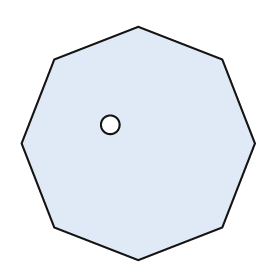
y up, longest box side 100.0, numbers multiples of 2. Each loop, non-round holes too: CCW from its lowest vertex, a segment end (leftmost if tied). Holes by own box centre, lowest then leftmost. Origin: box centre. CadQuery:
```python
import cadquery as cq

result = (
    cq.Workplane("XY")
    .moveTo(0.0, -50.0)
    .lineTo(36.0, -36.0)
    .lineTo(50.0, 0.0)
    .lineTo(36.0, 36.0)
    .lineTo(0.0, 50.0)
    .lineTo(-36.0, 36.0)
    .lineTo(-50.0, 0.0)
    .lineTo(-36.0, -36.0)
    .close()
    .moveTo(-12.0, 8.0)
    .circle(4.0)
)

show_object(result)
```